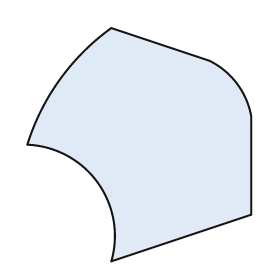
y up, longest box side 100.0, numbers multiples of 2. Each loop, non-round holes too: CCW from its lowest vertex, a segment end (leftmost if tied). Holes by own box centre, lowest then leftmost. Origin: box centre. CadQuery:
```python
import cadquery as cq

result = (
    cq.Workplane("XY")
    .moveTo(-12.0, -50.0)
    .lineTo(48.0, -30.0)
    .lineTo(48.0, 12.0)
    .threePointArc((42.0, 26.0), (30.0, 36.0))
    .lineTo(-12.0, 50.0)
    .threePointArc((-34.0, 28.0), (-48.0, 0.0))
    .threePointArc((-18.0, -16.0), (-12.0, -50.0))
    .close()
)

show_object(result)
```